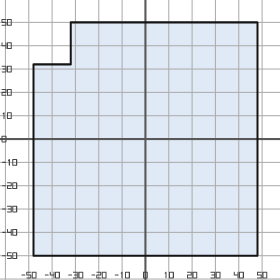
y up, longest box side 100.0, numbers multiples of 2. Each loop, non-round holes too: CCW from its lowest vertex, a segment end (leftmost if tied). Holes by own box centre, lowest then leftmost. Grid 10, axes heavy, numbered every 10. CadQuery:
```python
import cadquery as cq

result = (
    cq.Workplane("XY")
    .moveTo(-48.0, -50.0)
    .lineTo(48.0, -50.0)
    .lineTo(48.0, 50.0)
    .lineTo(-32.0, 50.0)
    .lineTo(-32.0, 32.0)
    .lineTo(-48.0, 32.0)
    .close()
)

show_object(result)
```